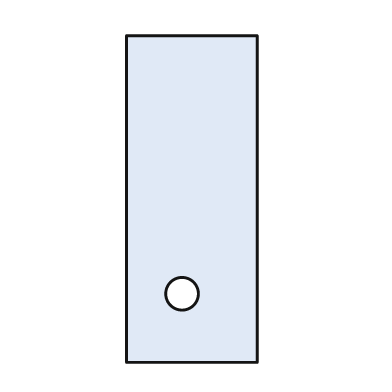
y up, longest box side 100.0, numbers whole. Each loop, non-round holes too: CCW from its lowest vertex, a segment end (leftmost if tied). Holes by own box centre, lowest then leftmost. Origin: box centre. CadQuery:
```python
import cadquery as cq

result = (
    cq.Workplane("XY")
    .moveTo(-20.0, -50.0)
    .lineTo(20.0, -50.0)
    .lineTo(20.0, 50.0)
    .lineTo(-20.0, 50.0)
    .close()
    .moveTo(-3.0, -29.0)
    .circle(5.0)
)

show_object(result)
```